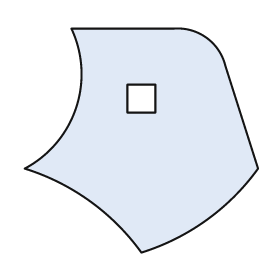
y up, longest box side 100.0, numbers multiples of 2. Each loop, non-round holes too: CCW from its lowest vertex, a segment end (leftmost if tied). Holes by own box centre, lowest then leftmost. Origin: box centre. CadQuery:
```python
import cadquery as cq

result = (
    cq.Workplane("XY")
    .moveTo(0.0, -48.0)
    .threePointArc((28.0, -34.0), (50.0, -12.0))
    .lineTo(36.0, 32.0)
    .threePointArc((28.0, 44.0), (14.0, 48.0))
    .lineTo(-30.0, 48.0)
    .threePointArc((-28.0, 14.0), (-50.0, -12.0))
    .threePointArc((-22.0, -26.0), (0.0, -48.0))
    .close()
    .moveTo(-6.0, 12.0)
    .lineTo(6.0, 12.0)
    .lineTo(6.0, 24.0)
    .lineTo(-6.0, 24.0)
    .close()
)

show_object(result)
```